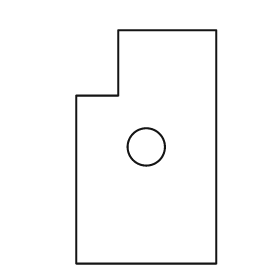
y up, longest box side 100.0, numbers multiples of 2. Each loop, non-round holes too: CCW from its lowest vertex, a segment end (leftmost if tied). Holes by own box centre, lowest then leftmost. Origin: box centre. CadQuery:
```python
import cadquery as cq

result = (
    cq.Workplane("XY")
    .moveTo(-30.0, -50.0)
    .lineTo(30.0, -50.0)
    .lineTo(30.0, 50.0)
    .lineTo(-12.0, 50.0)
    .lineTo(-12.0, 22.0)
    .lineTo(-30.0, 22.0)
    .close()
    .moveTo(0.0, 0.0)
    .circle(8.0)
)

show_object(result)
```